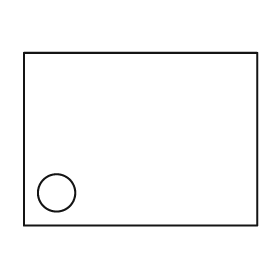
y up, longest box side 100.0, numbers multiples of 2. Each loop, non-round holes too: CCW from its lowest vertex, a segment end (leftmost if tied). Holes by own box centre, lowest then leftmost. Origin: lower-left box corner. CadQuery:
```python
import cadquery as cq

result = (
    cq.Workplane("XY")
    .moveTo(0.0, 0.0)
    .lineTo(100.0, 0.0)
    .lineTo(100.0, 74.0)
    .lineTo(0.0, 74.0)
    .close()
    .moveTo(14.0, 14.0)
    .circle(8.0)
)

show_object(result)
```